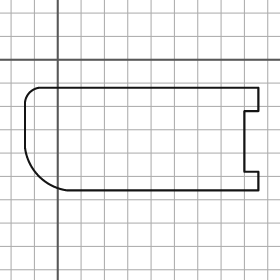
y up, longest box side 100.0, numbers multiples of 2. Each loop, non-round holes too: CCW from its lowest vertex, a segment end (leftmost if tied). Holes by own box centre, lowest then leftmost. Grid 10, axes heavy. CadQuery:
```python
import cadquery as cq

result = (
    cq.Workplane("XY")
    .moveTo(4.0, -56.0)
    .lineTo(86.0, -56.0)
    .lineTo(86.0, -48.0)
    .lineTo(80.0, -48.0)
    .lineTo(80.0, -22.0)
    .lineTo(86.0, -22.0)
    .lineTo(86.0, -12.0)
    .lineTo(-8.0, -12.0)
    .threePointArc((-12.0, -14.0), (-14.0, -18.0))
    .lineTo(-14.0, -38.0)
    .threePointArc((-8.0, -50.0), (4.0, -56.0))
    .close()
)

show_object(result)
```